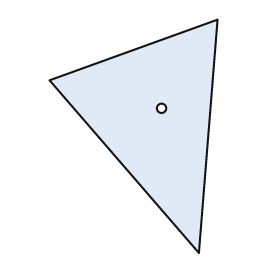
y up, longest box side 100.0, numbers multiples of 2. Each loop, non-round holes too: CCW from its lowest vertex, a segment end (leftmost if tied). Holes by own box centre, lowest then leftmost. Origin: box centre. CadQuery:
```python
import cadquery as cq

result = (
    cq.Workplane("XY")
    .moveTo(28.0, -50.0)
    .lineTo(36.0, 50.0)
    .lineTo(-36.0, 24.0)
    .close()
    .moveTo(12.0, 12.0)
    .circle(2.0)
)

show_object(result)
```